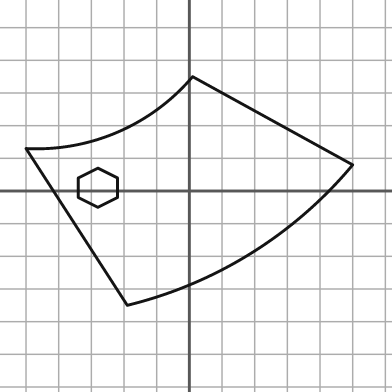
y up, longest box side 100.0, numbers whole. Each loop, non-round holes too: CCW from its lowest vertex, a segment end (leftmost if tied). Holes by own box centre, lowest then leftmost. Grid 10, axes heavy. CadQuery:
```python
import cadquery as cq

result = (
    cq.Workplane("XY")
    .moveTo(-19.0, -35.0)
    .threePointArc((19.0, -19.0), (50.0, 8.0))
    .lineTo(1.0, 35.0)
    .threePointArc((-22.0, 18.0), (-50.0, 13.0))
    .close()
    .moveTo(-28.0, -5.0)
    .lineTo(-22.0, -2.0)
    .lineTo(-22.0, 4.0)
    .lineTo(-28.0, 7.0)
    .lineTo(-34.0, 4.0)
    .lineTo(-34.0, -2.0)
    .close()
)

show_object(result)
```